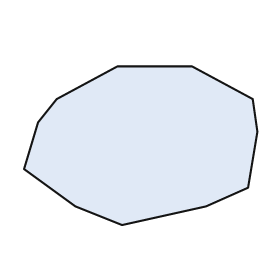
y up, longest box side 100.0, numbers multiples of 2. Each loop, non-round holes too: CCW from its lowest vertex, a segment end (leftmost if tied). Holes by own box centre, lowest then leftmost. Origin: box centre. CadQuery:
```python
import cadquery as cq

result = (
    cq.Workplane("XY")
    .moveTo(-8.0, -34.0)
    .lineTo(28.0, -26.0)
    .lineTo(46.0, -18.0)
    .lineTo(50.0, 6.0)
    .lineTo(48.0, 20.0)
    .lineTo(22.0, 34.0)
    .lineTo(-10.0, 34.0)
    .lineTo(-36.0, 20.0)
    .lineTo(-44.0, 10.0)
    .lineTo(-50.0, -10.0)
    .lineTo(-28.0, -26.0)
    .close()
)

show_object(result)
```